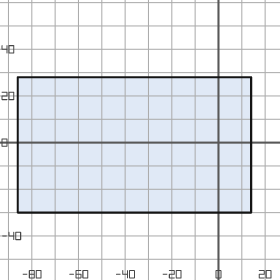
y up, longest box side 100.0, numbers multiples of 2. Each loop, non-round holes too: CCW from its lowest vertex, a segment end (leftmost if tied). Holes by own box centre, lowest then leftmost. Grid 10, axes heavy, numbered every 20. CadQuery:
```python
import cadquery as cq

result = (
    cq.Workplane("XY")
    .moveTo(-86.0, -30.0)
    .lineTo(14.0, -30.0)
    .lineTo(14.0, 28.0)
    .lineTo(-86.0, 28.0)
    .close()
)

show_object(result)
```